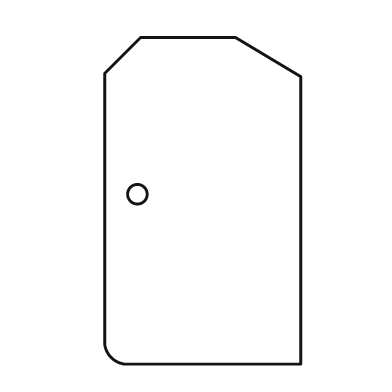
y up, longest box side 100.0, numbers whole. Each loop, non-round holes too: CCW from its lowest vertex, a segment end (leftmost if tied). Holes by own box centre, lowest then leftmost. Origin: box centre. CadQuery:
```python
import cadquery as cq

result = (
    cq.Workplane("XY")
    .moveTo(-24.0, -50.0)
    .lineTo(30.0, -50.0)
    .lineTo(30.0, 38.0)
    .lineTo(10.0, 50.0)
    .lineTo(-19.0, 50.0)
    .lineTo(-30.0, 39.0)
    .lineTo(-30.0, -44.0)
    .threePointArc((-28.0, -48.0), (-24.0, -50.0))
    .close()
    .moveTo(-20.0, 2.0)
    .circle(3.0)
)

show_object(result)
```